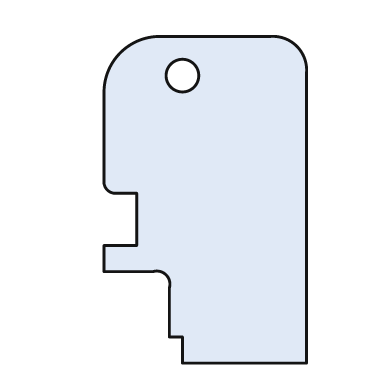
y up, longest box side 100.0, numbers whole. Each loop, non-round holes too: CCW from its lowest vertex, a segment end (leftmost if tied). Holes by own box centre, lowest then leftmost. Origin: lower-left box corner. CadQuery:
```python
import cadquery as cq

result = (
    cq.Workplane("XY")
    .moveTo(24.0, 0.0)
    .lineTo(62.0, 0.0)
    .lineTo(62.0, 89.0)
    .threePointArc((59.0, 97.0), (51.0, 100.0))
    .lineTo(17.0, 100.0)
    .threePointArc((5.0, 95.0), (0.0, 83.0))
    .lineTo(0.0, 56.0)
    .threePointArc((1.0, 53.0), (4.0, 52.0))
    .lineTo(10.0, 52.0)
    .lineTo(10.0, 36.0)
    .lineTo(0.0, 36.0)
    .lineTo(0.0, 28.0)
    .lineTo(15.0, 28.0)
    .threePointArc((19.0, 27.0), (20.0, 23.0))
    .lineTo(20.0, 8.0)
    .lineTo(24.0, 8.0)
    .close()
    .moveTo(24.0, 88.0)
    .circle(5.0)
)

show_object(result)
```